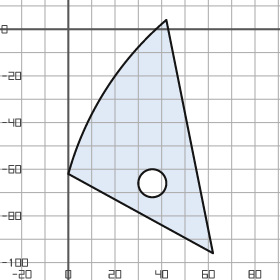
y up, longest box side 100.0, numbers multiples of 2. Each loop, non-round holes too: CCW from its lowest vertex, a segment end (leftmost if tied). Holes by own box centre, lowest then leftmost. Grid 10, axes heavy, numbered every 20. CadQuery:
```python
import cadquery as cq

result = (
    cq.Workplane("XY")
    .moveTo(62.0, -96.0)
    .lineTo(42.0, 4.0)
    .threePointArc((16.0, -26.0), (0.0, -62.0))
    .close()
    .moveTo(36.0, -66.0)
    .circle(6.0)
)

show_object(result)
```